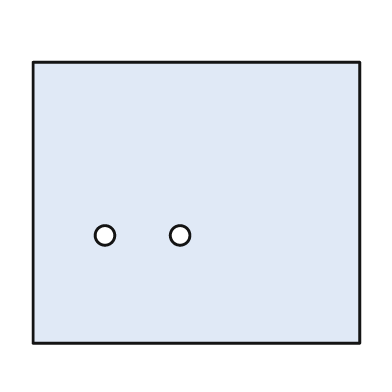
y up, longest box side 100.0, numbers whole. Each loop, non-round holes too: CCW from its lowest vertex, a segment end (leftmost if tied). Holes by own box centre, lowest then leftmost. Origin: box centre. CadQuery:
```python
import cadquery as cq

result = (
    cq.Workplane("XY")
    .moveTo(-50.0, -43.0)
    .lineTo(50.0, -43.0)
    .lineTo(50.0, 43.0)
    .lineTo(-50.0, 43.0)
    .close()
    .moveTo(-28.0, -10.0)
    .circle(3.0)
    .moveTo(-5.0, -10.0)
    .circle(3.0)
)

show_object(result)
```